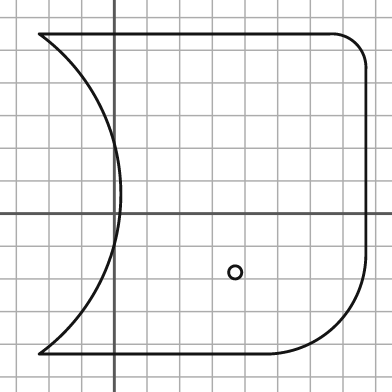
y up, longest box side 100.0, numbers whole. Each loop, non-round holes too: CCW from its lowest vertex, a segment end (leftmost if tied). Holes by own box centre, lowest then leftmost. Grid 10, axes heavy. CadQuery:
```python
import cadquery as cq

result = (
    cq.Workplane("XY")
    .moveTo(-23.0, -43.0)
    .lineTo(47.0, -43.0)
    .threePointArc((68.0, -34.0), (77.0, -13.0))
    .lineTo(77.0, 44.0)
    .threePointArc((74.0, 52.0), (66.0, 55.0))
    .lineTo(-23.0, 55.0)
    .threePointArc((2.0, 6.0), (-23.0, -43.0))
    .close()
    .moveTo(37.0, -18.0)
    .circle(2.0)
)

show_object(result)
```